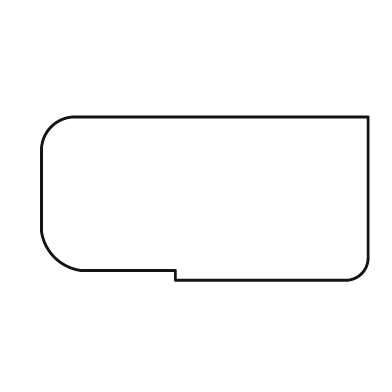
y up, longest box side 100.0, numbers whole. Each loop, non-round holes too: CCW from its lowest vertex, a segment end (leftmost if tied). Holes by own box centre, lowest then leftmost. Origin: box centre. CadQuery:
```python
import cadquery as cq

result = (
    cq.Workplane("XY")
    .moveTo(-9.0, -25.0)
    .lineTo(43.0, -25.0)
    .threePointArc((48.0, -23.0), (50.0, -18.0))
    .lineTo(50.0, 25.0)
    .lineTo(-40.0, 25.0)
    .threePointArc((-47.0, 22.0), (-50.0, 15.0))
    .lineTo(-50.0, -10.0)
    .threePointArc((-46.0, -18.0), (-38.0, -22.0))
    .lineTo(-9.0, -22.0)
    .close()
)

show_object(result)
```